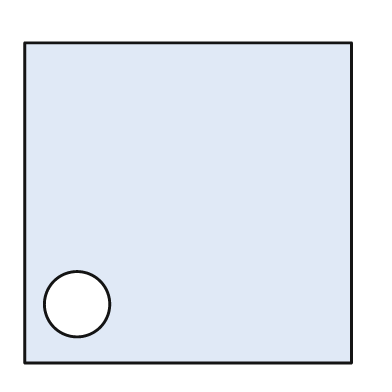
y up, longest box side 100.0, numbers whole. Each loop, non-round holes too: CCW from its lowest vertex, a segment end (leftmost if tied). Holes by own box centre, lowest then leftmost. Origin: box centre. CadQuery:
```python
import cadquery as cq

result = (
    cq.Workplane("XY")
    .moveTo(-50.0, -49.0)
    .lineTo(50.0, -49.0)
    .lineTo(50.0, 49.0)
    .lineTo(-50.0, 49.0)
    .close()
    .moveTo(-34.0, -31.0)
    .circle(10.0)
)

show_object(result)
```